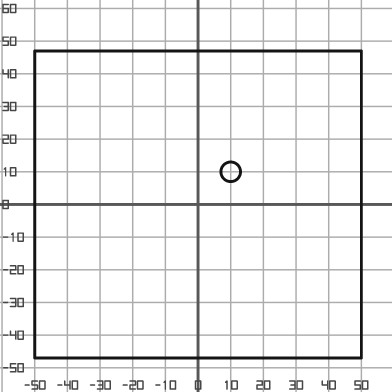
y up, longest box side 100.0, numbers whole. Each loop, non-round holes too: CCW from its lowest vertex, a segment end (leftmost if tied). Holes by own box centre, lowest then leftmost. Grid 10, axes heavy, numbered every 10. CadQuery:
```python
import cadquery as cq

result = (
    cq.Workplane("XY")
    .moveTo(-50.0, -47.0)
    .lineTo(50.0, -47.0)
    .lineTo(50.0, 47.0)
    .lineTo(-50.0, 47.0)
    .close()
    .moveTo(10.0, 10.0)
    .circle(3.0)
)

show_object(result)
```